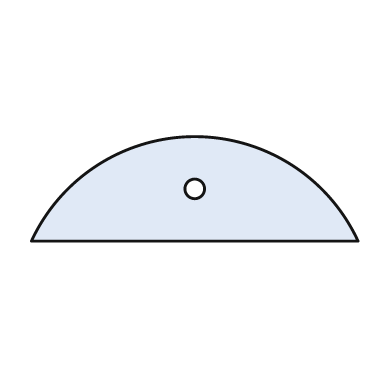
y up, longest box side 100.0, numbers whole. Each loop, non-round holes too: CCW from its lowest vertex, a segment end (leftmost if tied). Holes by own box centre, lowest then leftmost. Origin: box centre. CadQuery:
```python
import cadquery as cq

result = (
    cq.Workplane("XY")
    .moveTo(-50.0, -16.0)
    .lineTo(50.0, -16.0)
    .threePointArc((0.0, 16.0), (-50.0, -16.0))
    .close()
    .moveTo(0.0, 0.0)
    .circle(3.0)
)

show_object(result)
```